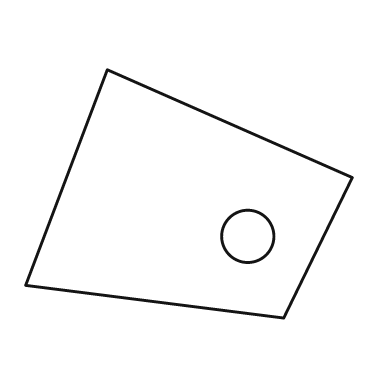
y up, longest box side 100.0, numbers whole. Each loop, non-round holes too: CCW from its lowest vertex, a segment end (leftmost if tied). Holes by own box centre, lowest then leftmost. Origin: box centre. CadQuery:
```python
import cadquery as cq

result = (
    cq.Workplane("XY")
    .moveTo(29.0, -38.0)
    .lineTo(50.0, 5.0)
    .lineTo(-25.0, 38.0)
    .lineTo(-50.0, -28.0)
    .close()
    .moveTo(18.0, -13.0)
    .circle(8.0)
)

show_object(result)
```